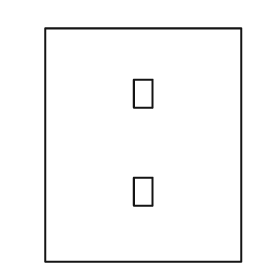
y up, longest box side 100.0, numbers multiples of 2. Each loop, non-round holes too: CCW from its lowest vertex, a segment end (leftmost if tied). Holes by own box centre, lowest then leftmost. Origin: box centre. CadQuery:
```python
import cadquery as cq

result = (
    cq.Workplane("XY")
    .moveTo(-42.0, -50.0)
    .lineTo(42.0, -50.0)
    .lineTo(42.0, 50.0)
    .lineTo(-42.0, 50.0)
    .close()
    .moveTo(-4.0, -26.0)
    .lineTo(4.0, -26.0)
    .lineTo(4.0, -14.0)
    .lineTo(-4.0, -14.0)
    .close()
    .moveTo(-4.0, 16.0)
    .lineTo(4.0, 16.0)
    .lineTo(4.0, 28.0)
    .lineTo(-4.0, 28.0)
    .close()
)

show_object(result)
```